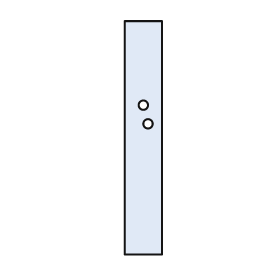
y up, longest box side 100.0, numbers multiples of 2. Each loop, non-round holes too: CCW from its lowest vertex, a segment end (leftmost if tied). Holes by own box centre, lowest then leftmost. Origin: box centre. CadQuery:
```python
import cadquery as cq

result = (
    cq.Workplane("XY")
    .moveTo(-8.0, -50.0)
    .lineTo(8.0, -50.0)
    .lineTo(8.0, 50.0)
    .lineTo(-8.0, 50.0)
    .close()
    .moveTo(2.0, 6.0)
    .circle(2.0)
    .moveTo(0.0, 14.0)
    .circle(2.0)
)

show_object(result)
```